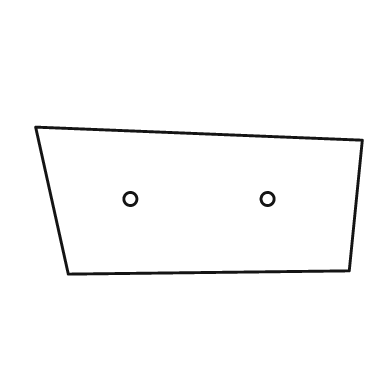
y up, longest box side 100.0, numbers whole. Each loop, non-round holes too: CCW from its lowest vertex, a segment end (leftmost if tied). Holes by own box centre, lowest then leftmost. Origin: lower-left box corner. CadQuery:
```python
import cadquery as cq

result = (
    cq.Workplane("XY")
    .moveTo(10.0, 0.0)
    .lineTo(96.0, 1.0)
    .lineTo(100.0, 41.0)
    .lineTo(0.0, 45.0)
    .close()
    .moveTo(29.0, 23.0)
    .circle(2.0)
    .moveTo(71.0, 23.0)
    .circle(2.0)
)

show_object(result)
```